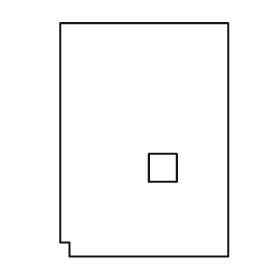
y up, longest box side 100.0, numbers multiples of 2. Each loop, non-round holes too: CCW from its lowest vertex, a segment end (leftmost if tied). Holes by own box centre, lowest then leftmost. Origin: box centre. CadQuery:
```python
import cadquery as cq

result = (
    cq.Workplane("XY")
    .moveTo(-32.0, -50.0)
    .lineTo(36.0, -50.0)
    .lineTo(36.0, 50.0)
    .lineTo(-36.0, 50.0)
    .lineTo(-36.0, -44.0)
    .lineTo(-32.0, -44.0)
    .close()
    .moveTo(2.0, -18.0)
    .lineTo(14.0, -18.0)
    .lineTo(14.0, -6.0)
    .lineTo(2.0, -6.0)
    .close()
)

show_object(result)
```